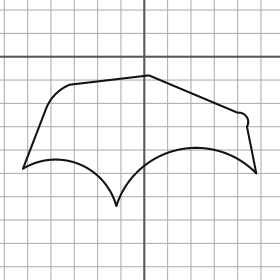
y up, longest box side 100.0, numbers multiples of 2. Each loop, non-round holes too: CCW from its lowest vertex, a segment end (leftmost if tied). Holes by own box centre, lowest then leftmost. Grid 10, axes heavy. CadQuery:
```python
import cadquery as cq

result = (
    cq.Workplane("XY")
    .moveTo(-12.0, -64.0)
    .threePointArc((14.0, -40.0), (48.0, -50.0))
    .lineTo(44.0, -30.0)
    .threePointArc((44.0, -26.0), (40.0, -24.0))
    .lineTo(2.0, -8.0)
    .lineTo(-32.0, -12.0)
    .threePointArc((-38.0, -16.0), (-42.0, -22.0))
    .lineTo(-52.0, -48.0)
    .threePointArc((-28.0, -46.0), (-12.0, -64.0))
    .close()
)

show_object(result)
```